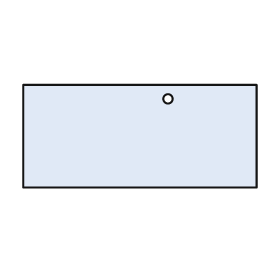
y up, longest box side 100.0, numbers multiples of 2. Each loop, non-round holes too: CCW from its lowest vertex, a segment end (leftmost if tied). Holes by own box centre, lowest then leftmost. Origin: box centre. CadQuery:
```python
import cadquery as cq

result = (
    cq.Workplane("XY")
    .moveTo(-50.0, -22.0)
    .lineTo(50.0, -22.0)
    .lineTo(50.0, 22.0)
    .lineTo(-50.0, 22.0)
    .close()
    .moveTo(12.0, 16.0)
    .circle(2.0)
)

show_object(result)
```